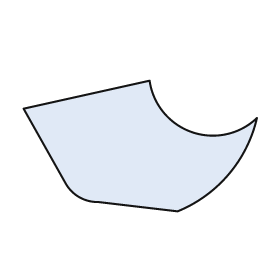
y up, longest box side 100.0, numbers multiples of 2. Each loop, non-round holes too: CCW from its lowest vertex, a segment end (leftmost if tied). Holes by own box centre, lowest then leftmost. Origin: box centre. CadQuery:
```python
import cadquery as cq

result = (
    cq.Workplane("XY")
    .moveTo(16.0, -28.0)
    .threePointArc((38.0, -12.0), (50.0, 12.0))
    .threePointArc((22.0, 6.0), (4.0, 28.0))
    .lineTo(-50.0, 16.0)
    .lineTo(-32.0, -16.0)
    .threePointArc((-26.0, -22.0), (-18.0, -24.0))
    .close()
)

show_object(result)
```